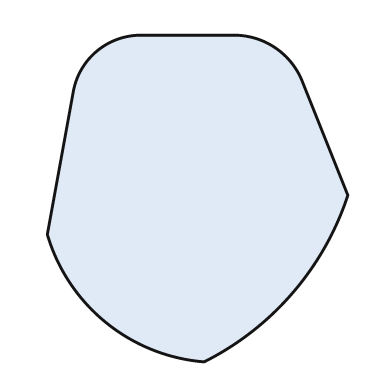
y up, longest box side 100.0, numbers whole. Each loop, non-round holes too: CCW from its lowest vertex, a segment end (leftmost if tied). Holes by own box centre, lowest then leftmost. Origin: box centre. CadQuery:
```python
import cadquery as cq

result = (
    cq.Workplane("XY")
    .moveTo(2.0, -50.0)
    .threePointArc((29.0, -29.0), (46.0, 1.0))
    .lineTo(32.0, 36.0)
    .threePointArc((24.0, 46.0), (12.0, 50.0))
    .lineTo(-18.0, 50.0)
    .threePointArc((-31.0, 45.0), (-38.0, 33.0))
    .lineTo(-46.0, -11.0)
    .threePointArc((-28.0, -38.0), (2.0, -50.0))
    .close()
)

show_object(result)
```